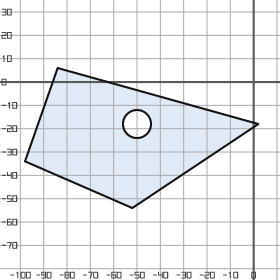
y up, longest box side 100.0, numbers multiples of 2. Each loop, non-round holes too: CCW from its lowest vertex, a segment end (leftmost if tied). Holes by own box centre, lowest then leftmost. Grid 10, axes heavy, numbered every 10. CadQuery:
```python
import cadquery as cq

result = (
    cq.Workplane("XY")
    .moveTo(-52.0, -54.0)
    .lineTo(2.0, -18.0)
    .lineTo(-84.0, 6.0)
    .lineTo(-98.0, -34.0)
    .close()
    .moveTo(-50.0, -18.0)
    .circle(6.0)
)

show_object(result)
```